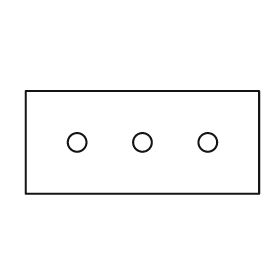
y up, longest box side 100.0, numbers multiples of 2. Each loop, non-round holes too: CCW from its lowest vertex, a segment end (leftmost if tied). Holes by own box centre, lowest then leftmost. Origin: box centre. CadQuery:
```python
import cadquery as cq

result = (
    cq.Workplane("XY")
    .moveTo(-50.0, -22.0)
    .lineTo(50.0, -22.0)
    .lineTo(50.0, 22.0)
    .lineTo(-50.0, 22.0)
    .close()
    .moveTo(-28.0, 0.0)
    .circle(4.0)
    .moveTo(0.0, 0.0)
    .circle(4.0)
    .moveTo(28.0, 0.0)
    .circle(4.0)
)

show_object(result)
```